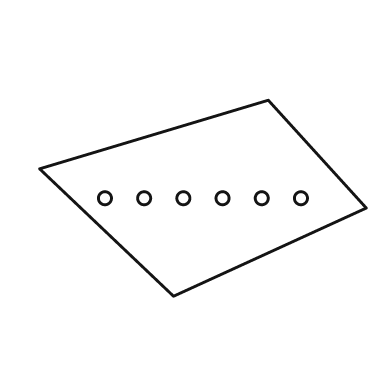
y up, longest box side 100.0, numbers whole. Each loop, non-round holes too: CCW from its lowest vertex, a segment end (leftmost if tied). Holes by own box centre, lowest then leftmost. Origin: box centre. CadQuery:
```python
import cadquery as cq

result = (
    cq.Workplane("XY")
    .moveTo(-9.0, -30.0)
    .lineTo(50.0, -3.0)
    .lineTo(20.0, 30.0)
    .lineTo(-50.0, 9.0)
    .close()
    .moveTo(-30.0, 0.0)
    .circle(2.0)
    .moveTo(-18.0, 0.0)
    .circle(2.0)
    .moveTo(-6.0, 0.0)
    .circle(2.0)
    .moveTo(6.0, 0.0)
    .circle(2.0)
    .moveTo(18.0, 0.0)
    .circle(2.0)
    .moveTo(30.0, 0.0)
    .circle(2.0)
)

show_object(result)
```